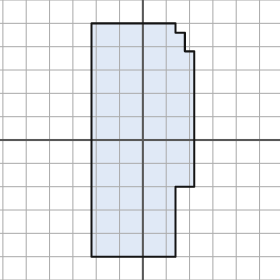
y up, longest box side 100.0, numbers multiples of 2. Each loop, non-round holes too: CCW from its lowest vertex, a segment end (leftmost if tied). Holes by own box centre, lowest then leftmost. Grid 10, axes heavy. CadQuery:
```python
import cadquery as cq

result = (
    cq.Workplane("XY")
    .moveTo(-22.0, -50.0)
    .lineTo(14.0, -50.0)
    .lineTo(14.0, -20.0)
    .lineTo(22.0, -20.0)
    .lineTo(22.0, 38.0)
    .lineTo(18.0, 38.0)
    .lineTo(18.0, 46.0)
    .lineTo(14.0, 46.0)
    .lineTo(14.0, 50.0)
    .lineTo(-22.0, 50.0)
    .close()
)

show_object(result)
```